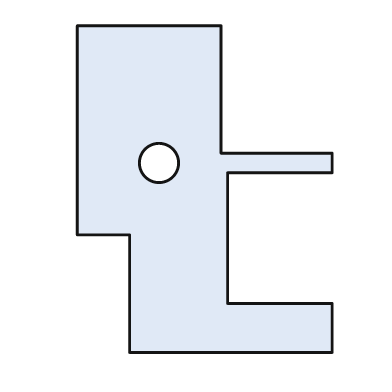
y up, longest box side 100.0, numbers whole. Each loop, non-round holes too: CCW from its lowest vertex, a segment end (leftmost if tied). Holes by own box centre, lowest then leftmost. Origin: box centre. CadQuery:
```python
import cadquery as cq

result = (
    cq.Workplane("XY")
    .moveTo(-23.0, -50.0)
    .lineTo(39.0, -50.0)
    .lineTo(39.0, -35.0)
    .lineTo(7.0, -35.0)
    .lineTo(7.0, 5.0)
    .lineTo(39.0, 5.0)
    .lineTo(39.0, 11.0)
    .lineTo(5.0, 11.0)
    .lineTo(5.0, 50.0)
    .lineTo(-39.0, 50.0)
    .lineTo(-39.0, -14.0)
    .lineTo(-23.0, -14.0)
    .close()
    .moveTo(-14.0, 8.0)
    .circle(6.0)
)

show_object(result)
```